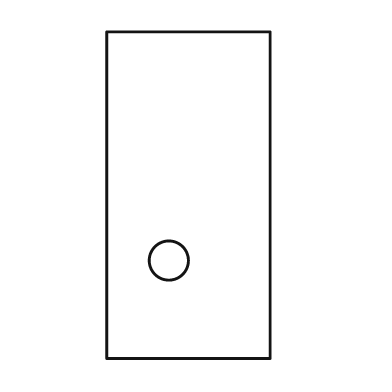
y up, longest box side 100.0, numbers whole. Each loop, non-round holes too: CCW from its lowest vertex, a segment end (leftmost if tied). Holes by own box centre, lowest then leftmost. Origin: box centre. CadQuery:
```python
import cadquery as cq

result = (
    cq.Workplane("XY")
    .moveTo(-25.0, -50.0)
    .lineTo(25.0, -50.0)
    .lineTo(25.0, 50.0)
    .lineTo(-25.0, 50.0)
    .close()
    .moveTo(-6.0, -20.0)
    .circle(6.0)
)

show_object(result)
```